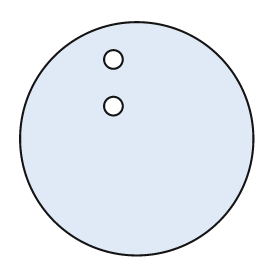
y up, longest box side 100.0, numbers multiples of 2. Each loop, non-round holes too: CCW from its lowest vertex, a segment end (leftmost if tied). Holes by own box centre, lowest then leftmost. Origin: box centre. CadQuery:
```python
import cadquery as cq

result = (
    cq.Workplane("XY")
    .moveTo(0.0, 0.0)
    .circle(50.0)
    .moveTo(-10.0, 14.0)
    .circle(4.0)
    .moveTo(-10.0, 34.0)
    .circle(4.0)
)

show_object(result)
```